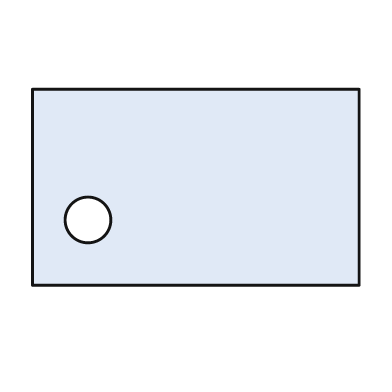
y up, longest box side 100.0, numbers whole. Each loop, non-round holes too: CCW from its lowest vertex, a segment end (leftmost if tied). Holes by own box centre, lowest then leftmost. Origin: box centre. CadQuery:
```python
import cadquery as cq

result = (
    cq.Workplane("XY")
    .moveTo(-50.0, -30.0)
    .lineTo(50.0, -30.0)
    .lineTo(50.0, 30.0)
    .lineTo(-50.0, 30.0)
    .close()
    .moveTo(-33.0, -10.0)
    .circle(7.0)
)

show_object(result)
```